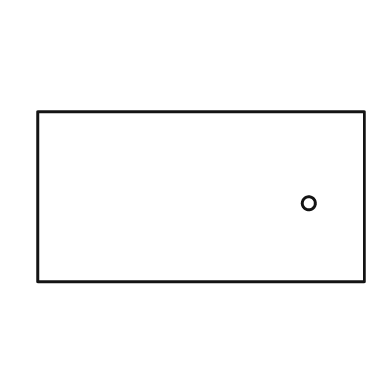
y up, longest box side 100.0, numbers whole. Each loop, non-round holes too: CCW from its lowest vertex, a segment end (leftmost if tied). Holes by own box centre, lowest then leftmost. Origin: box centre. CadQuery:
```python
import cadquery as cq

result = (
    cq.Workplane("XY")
    .moveTo(-50.0, -26.0)
    .lineTo(50.0, -26.0)
    .lineTo(50.0, 26.0)
    .lineTo(-50.0, 26.0)
    .close()
    .moveTo(33.0, -2.0)
    .circle(2.0)
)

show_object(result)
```